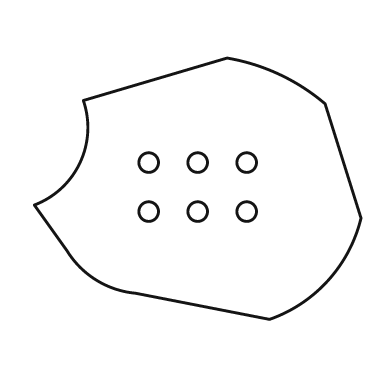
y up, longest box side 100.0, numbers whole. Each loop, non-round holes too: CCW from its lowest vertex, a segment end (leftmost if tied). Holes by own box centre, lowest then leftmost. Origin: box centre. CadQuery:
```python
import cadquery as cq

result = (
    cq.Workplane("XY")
    .moveTo(22.0, -40.0)
    .threePointArc((40.0, -28.0), (50.0, -9.0))
    .lineTo(39.0, 26.0)
    .threePointArc((25.0, 35.0), (9.0, 40.0))
    .lineTo(-35.0, 27.0)
    .threePointArc((-36.0, 8.0), (-50.0, -5.0))
    .lineTo(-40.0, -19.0)
    .threePointArc((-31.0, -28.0), (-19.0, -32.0))
    .close()
    .moveTo(-15.0, -7.0)
    .circle(3.0)
    .moveTo(0.0, -7.0)
    .circle(3.0)
    .moveTo(15.0, -7.0)
    .circle(3.0)
    .moveTo(-15.0, 8.0)
    .circle(3.0)
    .moveTo(0.0, 8.0)
    .circle(3.0)
    .moveTo(15.0, 8.0)
    .circle(3.0)
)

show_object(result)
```